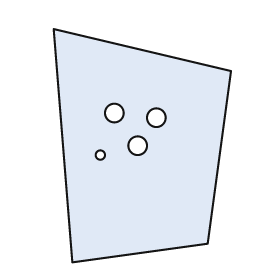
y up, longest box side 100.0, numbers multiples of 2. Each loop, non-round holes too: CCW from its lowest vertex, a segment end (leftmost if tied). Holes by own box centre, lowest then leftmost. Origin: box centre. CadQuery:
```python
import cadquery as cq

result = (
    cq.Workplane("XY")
    .moveTo(-30.0, -50.0)
    .lineTo(28.0, -42.0)
    .lineTo(38.0, 32.0)
    .lineTo(-38.0, 50.0)
    .close()
    .moveTo(-18.0, -4.0)
    .circle(2.0)
    .moveTo(-2.0, 0.0)
    .circle(4.0)
    .moveTo(6.0, 12.0)
    .circle(4.0)
    .moveTo(-12.0, 14.0)
    .circle(4.0)
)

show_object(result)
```